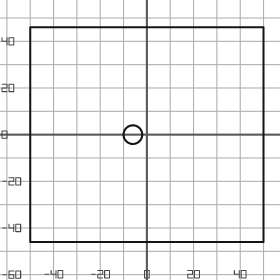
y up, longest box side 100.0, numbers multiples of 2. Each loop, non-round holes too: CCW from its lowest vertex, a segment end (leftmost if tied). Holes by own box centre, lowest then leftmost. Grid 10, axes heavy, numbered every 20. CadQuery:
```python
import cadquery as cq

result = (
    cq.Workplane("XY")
    .moveTo(-50.0, -46.0)
    .lineTo(50.0, -46.0)
    .lineTo(50.0, 46.0)
    .lineTo(-50.0, 46.0)
    .close()
    .moveTo(-6.0, 0.0)
    .circle(4.0)
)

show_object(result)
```